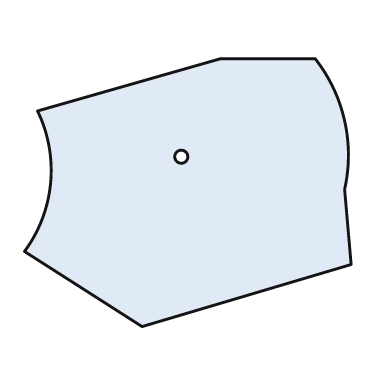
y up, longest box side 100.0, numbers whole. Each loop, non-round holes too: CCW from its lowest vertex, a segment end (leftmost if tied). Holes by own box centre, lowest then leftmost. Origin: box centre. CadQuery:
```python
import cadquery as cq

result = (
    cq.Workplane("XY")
    .moveTo(-14.0, -41.0)
    .lineTo(50.0, -22.0)
    .lineTo(48.0, 1.0)
    .threePointArc((48.0, 22.0), (39.0, 41.0))
    .lineTo(10.0, 41.0)
    .lineTo(-46.0, 25.0)
    .threePointArc((-42.0, 3.0), (-50.0, -18.0))
    .close()
    .moveTo(-2.0, 11.0)
    .circle(2.0)
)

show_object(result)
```